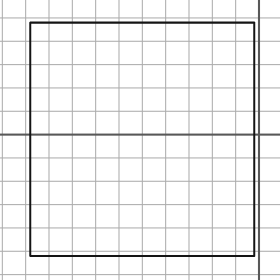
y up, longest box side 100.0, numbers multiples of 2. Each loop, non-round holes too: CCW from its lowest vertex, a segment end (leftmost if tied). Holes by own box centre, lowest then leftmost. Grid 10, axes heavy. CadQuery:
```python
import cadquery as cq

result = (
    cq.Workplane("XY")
    .moveTo(-98.0, -52.0)
    .lineTo(-2.0, -52.0)
    .lineTo(-2.0, 48.0)
    .lineTo(-98.0, 48.0)
    .close()
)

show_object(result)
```